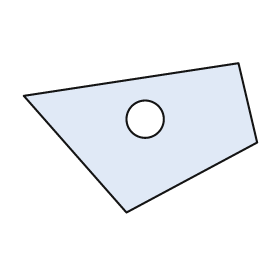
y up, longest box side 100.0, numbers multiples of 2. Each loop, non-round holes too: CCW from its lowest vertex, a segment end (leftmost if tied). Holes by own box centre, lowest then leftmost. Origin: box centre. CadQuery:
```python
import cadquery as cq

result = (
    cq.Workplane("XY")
    .moveTo(-6.0, -32.0)
    .lineTo(50.0, -2.0)
    .lineTo(42.0, 32.0)
    .lineTo(-50.0, 18.0)
    .close()
    .moveTo(2.0, 8.0)
    .circle(8.0)
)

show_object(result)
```